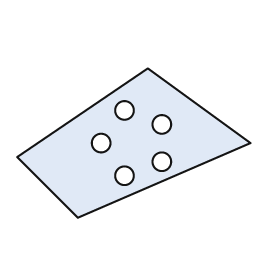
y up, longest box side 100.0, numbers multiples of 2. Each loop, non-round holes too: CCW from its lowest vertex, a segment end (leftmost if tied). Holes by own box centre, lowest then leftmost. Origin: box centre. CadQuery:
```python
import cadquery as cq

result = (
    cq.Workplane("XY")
    .moveTo(-24.0, -32.0)
    .lineTo(50.0, 0.0)
    .lineTo(6.0, 32.0)
    .lineTo(-50.0, -6.0)
    .close()
    .moveTo(-4.0, -14.0)
    .circle(4.0)
    .moveTo(12.0, -8.0)
    .circle(4.0)
    .moveTo(-14.0, 0.0)
    .circle(4.0)
    .moveTo(12.0, 8.0)
    .circle(4.0)
    .moveTo(-4.0, 14.0)
    .circle(4.0)
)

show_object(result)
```